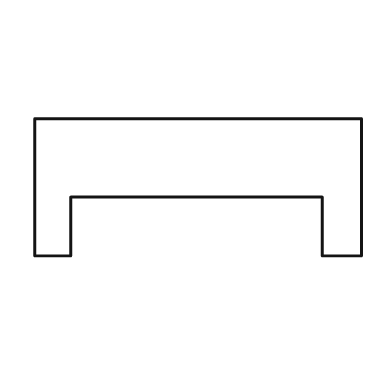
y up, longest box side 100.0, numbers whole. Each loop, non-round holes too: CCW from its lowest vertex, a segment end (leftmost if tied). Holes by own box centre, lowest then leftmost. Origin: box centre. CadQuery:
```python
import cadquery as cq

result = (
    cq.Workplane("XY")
    .moveTo(-50.0, -21.0)
    .lineTo(-39.0, -21.0)
    .lineTo(-39.0, -3.0)
    .lineTo(38.0, -3.0)
    .lineTo(38.0, -21.0)
    .lineTo(50.0, -21.0)
    .lineTo(50.0, 21.0)
    .lineTo(-50.0, 21.0)
    .close()
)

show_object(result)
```